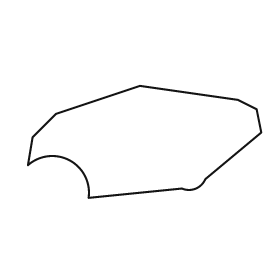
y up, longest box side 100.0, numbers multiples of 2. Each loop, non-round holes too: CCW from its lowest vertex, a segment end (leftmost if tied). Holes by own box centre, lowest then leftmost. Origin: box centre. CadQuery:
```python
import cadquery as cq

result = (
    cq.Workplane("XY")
    .moveTo(-24.0, -24.0)
    .lineTo(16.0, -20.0)
    .threePointArc((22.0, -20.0), (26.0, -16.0))
    .lineTo(50.0, 4.0)
    .lineTo(48.0, 14.0)
    .lineTo(40.0, 18.0)
    .lineTo(-2.0, 24.0)
    .lineTo(-38.0, 12.0)
    .lineTo(-48.0, 2.0)
    .lineTo(-50.0, -10.0)
    .threePointArc((-32.0, -8.0), (-24.0, -24.0))
    .close()
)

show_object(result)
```